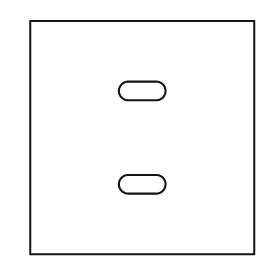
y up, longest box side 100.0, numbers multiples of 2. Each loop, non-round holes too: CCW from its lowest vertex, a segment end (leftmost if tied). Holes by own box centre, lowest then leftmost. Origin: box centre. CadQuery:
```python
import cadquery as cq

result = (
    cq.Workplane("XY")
    .moveTo(-48.0, -50.0)
    .lineTo(48.0, -50.0)
    .lineTo(48.0, 50.0)
    .lineTo(-48.0, 50.0)
    .close()
    .moveTo(-6.0, -24.0)
    .lineTo(6.0, -24.0)
    .threePointArc((10.0, -20.0), (6.0, -16.0))
    .lineTo(-6.0, -16.0)
    .threePointArc((-10.0, -20.0), (-6.0, -24.0))
    .close()
    .moveTo(-6.0, 16.0)
    .lineTo(6.0, 16.0)
    .threePointArc((10.0, 20.0), (6.0, 24.0))
    .lineTo(-6.0, 24.0)
    .threePointArc((-10.0, 20.0), (-6.0, 16.0))
    .close()
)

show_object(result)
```